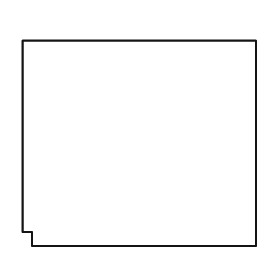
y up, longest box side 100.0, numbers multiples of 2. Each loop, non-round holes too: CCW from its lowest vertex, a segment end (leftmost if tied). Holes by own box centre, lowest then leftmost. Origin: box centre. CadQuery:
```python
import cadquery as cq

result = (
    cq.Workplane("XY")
    .moveTo(-46.0, -44.0)
    .lineTo(50.0, -44.0)
    .lineTo(50.0, 44.0)
    .lineTo(-50.0, 44.0)
    .lineTo(-50.0, -38.0)
    .lineTo(-46.0, -38.0)
    .close()
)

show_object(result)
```